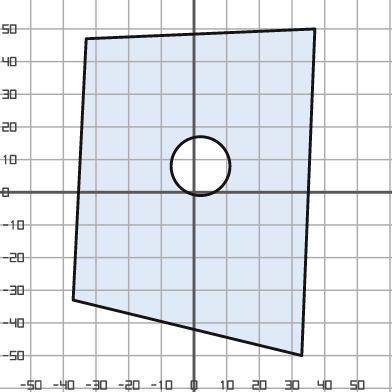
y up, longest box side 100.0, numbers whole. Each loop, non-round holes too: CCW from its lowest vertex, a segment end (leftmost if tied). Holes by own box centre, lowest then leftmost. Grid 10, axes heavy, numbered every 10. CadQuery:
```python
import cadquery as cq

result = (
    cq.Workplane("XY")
    .moveTo(33.0, -50.0)
    .lineTo(37.0, 50.0)
    .lineTo(-33.0, 47.0)
    .lineTo(-37.0, -33.0)
    .close()
    .moveTo(2.0, 8.0)
    .circle(9.0)
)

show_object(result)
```